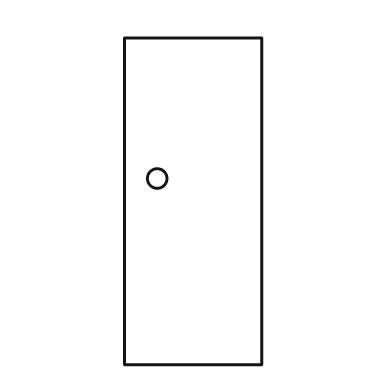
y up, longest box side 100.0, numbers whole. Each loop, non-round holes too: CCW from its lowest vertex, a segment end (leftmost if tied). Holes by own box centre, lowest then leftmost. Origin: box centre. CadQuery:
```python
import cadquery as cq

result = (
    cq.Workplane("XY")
    .moveTo(-21.0, -50.0)
    .lineTo(21.0, -50.0)
    .lineTo(21.0, 50.0)
    .lineTo(-21.0, 50.0)
    .close()
    .moveTo(-11.0, 7.0)
    .circle(3.0)
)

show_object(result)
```